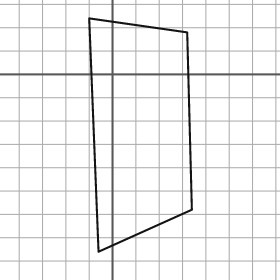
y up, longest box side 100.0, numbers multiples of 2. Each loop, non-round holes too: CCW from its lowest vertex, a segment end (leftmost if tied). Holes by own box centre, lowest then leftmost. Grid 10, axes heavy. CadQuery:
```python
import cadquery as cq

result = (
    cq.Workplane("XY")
    .moveTo(-6.0, -76.0)
    .lineTo(34.0, -58.0)
    .lineTo(32.0, 18.0)
    .lineTo(-10.0, 24.0)
    .close()
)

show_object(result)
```